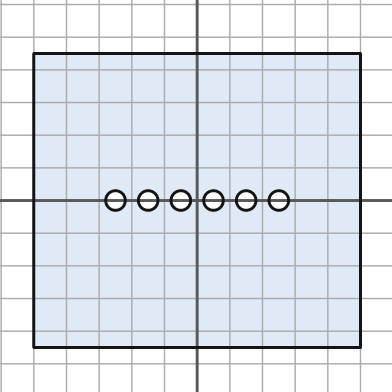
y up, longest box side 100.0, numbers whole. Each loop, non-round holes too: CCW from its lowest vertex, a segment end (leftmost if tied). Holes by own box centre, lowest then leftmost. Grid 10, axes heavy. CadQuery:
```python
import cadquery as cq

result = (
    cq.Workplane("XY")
    .moveTo(-50.0, -45.0)
    .lineTo(50.0, -45.0)
    .lineTo(50.0, 45.0)
    .lineTo(-50.0, 45.0)
    .close()
    .moveTo(-25.0, 0.0)
    .circle(3.0)
    .moveTo(-15.0, 0.0)
    .circle(3.0)
    .moveTo(-5.0, 0.0)
    .circle(3.0)
    .moveTo(5.0, 0.0)
    .circle(3.0)
    .moveTo(15.0, 0.0)
    .circle(3.0)
    .moveTo(25.0, 0.0)
    .circle(3.0)
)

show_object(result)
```